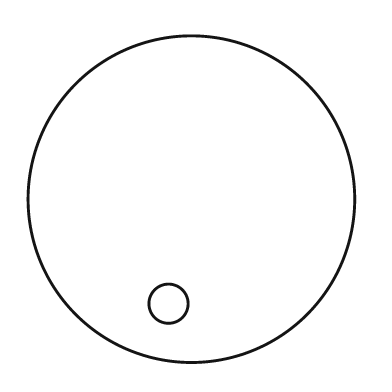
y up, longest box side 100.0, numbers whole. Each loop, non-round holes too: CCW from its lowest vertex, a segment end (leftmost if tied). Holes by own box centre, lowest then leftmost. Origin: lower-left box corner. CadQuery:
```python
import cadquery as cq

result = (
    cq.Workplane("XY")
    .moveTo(50.0, 50.0)
    .circle(50.0)
    .moveTo(43.0, 18.0)
    .circle(6.0)
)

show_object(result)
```